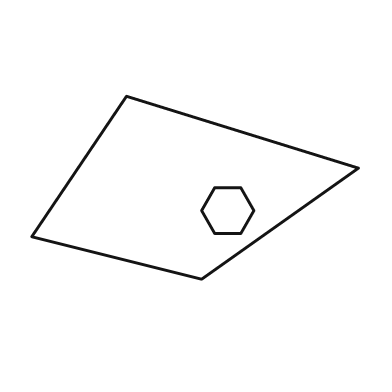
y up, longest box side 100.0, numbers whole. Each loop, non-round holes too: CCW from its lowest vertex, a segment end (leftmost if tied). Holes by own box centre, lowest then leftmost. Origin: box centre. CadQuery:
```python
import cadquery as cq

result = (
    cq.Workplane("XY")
    .moveTo(2.0, -28.0)
    .lineTo(50.0, 6.0)
    .lineTo(-21.0, 28.0)
    .lineTo(-50.0, -15.0)
    .close()
    .moveTo(6.0, -14.0)
    .lineTo(14.0, -14.0)
    .lineTo(18.0, -7.0)
    .lineTo(14.0, 0.0)
    .lineTo(6.0, 0.0)
    .lineTo(2.0, -7.0)
    .close()
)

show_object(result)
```